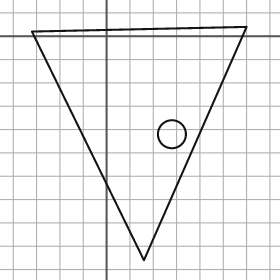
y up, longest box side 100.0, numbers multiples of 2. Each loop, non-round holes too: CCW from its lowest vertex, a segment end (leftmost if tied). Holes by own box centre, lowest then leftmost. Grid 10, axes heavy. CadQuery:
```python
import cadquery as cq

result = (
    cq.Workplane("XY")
    .moveTo(16.0, -96.0)
    .lineTo(60.0, 4.0)
    .lineTo(-32.0, 2.0)
    .close()
    .moveTo(28.0, -42.0)
    .circle(6.0)
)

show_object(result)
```